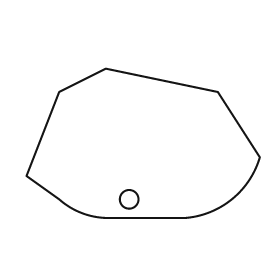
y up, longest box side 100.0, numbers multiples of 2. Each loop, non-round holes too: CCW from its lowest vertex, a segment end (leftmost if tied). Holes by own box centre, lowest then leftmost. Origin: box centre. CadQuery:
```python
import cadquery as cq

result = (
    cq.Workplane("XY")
    .moveTo(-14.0, -32.0)
    .lineTo(18.0, -32.0)
    .threePointArc((38.0, -24.0), (50.0, -6.0))
    .lineTo(32.0, 22.0)
    .lineTo(-16.0, 32.0)
    .lineTo(-36.0, 22.0)
    .lineTo(-50.0, -14.0)
    .lineTo(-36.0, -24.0)
    .threePointArc((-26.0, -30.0), (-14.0, -32.0))
    .close()
    .moveTo(-6.0, -24.0)
    .circle(4.0)
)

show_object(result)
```